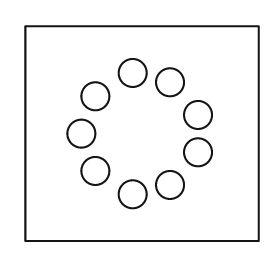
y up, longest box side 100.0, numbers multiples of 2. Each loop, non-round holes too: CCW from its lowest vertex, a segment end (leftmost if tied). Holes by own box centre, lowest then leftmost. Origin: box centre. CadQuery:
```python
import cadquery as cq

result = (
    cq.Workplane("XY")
    .moveTo(-50.0, -46.0)
    .lineTo(50.0, -46.0)
    .lineTo(50.0, 46.0)
    .lineTo(-50.0, 46.0)
    .close()
    .moveTo(-4.0, -26.0)
    .circle(6.0)
    .moveTo(12.0, -22.0)
    .circle(6.0)
    .moveTo(-20.0, -16.0)
    .circle(6.0)
    .moveTo(24.0, -8.0)
    .circle(6.0)
    .moveTo(-26.0, 0.0)
    .circle(6.0)
    .moveTo(24.0, 8.0)
    .circle(6.0)
    .moveTo(-20.0, 16.0)
    .circle(6.0)
    .moveTo(12.0, 22.0)
    .circle(6.0)
    .moveTo(-4.0, 26.0)
    .circle(6.0)
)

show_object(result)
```